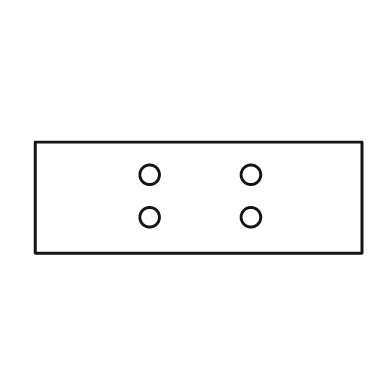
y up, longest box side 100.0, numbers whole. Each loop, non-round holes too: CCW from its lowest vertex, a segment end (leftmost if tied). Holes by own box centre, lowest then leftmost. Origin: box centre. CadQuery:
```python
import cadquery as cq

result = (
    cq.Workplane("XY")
    .moveTo(-50.0, -17.0)
    .lineTo(50.0, -17.0)
    .lineTo(50.0, 17.0)
    .lineTo(-50.0, 17.0)
    .close()
    .moveTo(-15.0, -6.0)
    .circle(3.0)
    .moveTo(16.0, -6.0)
    .circle(3.0)
    .moveTo(-15.0, 7.0)
    .circle(3.0)
    .moveTo(16.0, 7.0)
    .circle(3.0)
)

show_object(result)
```